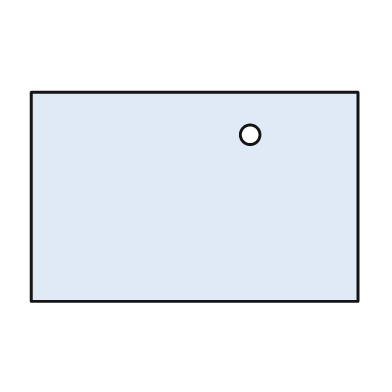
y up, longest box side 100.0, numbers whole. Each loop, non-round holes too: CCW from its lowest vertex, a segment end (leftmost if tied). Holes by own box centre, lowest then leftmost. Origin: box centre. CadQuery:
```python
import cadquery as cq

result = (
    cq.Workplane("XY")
    .moveTo(-50.0, -32.0)
    .lineTo(50.0, -32.0)
    .lineTo(50.0, 32.0)
    .lineTo(-50.0, 32.0)
    .close()
    .moveTo(17.0, 19.0)
    .circle(3.0)
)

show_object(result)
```